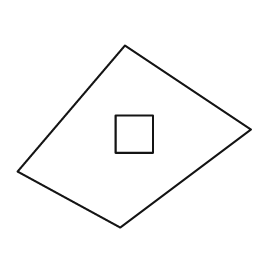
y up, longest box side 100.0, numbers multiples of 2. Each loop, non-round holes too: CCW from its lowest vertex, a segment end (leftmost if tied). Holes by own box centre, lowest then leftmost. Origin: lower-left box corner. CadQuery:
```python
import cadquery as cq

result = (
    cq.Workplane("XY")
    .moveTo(44.0, 0.0)
    .lineTo(100.0, 42.0)
    .lineTo(46.0, 78.0)
    .lineTo(0.0, 24.0)
    .close()
    .moveTo(42.0, 32.0)
    .lineTo(58.0, 32.0)
    .lineTo(58.0, 48.0)
    .lineTo(42.0, 48.0)
    .close()
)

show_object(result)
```